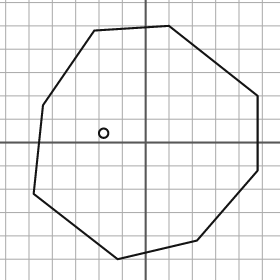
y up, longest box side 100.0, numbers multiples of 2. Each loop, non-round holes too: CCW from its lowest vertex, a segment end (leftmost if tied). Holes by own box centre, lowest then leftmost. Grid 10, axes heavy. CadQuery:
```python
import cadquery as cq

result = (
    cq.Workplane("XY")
    .moveTo(-12.0, -50.0)
    .lineTo(22.0, -42.0)
    .lineTo(48.0, -12.0)
    .lineTo(48.0, 20.0)
    .lineTo(10.0, 50.0)
    .lineTo(-22.0, 48.0)
    .lineTo(-44.0, 16.0)
    .lineTo(-48.0, -22.0)
    .close()
    .moveTo(-18.0, 4.0)
    .circle(2.0)
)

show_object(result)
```